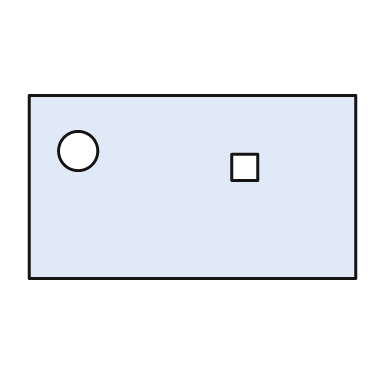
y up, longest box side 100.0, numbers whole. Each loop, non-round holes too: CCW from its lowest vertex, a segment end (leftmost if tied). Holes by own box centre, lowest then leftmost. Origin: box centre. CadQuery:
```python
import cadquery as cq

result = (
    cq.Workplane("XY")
    .moveTo(-50.0, -28.0)
    .lineTo(50.0, -28.0)
    .lineTo(50.0, 28.0)
    .lineTo(-50.0, 28.0)
    .close()
    .moveTo(12.0, 2.0)
    .lineTo(20.0, 2.0)
    .lineTo(20.0, 10.0)
    .lineTo(12.0, 10.0)
    .close()
    .moveTo(-35.0, 11.0)
    .circle(6.0)
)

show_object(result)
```